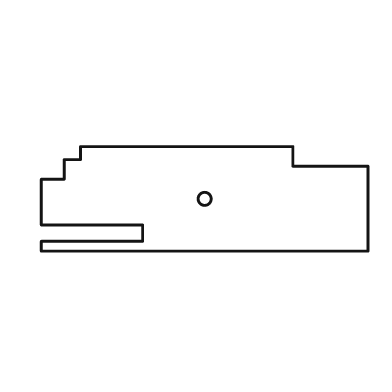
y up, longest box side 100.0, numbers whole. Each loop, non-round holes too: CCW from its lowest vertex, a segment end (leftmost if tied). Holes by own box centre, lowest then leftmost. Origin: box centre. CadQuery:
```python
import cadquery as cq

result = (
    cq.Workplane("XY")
    .moveTo(-50.0, -16.0)
    .lineTo(50.0, -16.0)
    .lineTo(50.0, 10.0)
    .lineTo(27.0, 10.0)
    .lineTo(27.0, 16.0)
    .lineTo(-38.0, 16.0)
    .lineTo(-38.0, 12.0)
    .lineTo(-43.0, 12.0)
    .lineTo(-43.0, 6.0)
    .lineTo(-50.0, 6.0)
    .lineTo(-50.0, -8.0)
    .lineTo(-19.0, -8.0)
    .lineTo(-19.0, -13.0)
    .lineTo(-50.0, -13.0)
    .close()
    .moveTo(0.0, 0.0)
    .circle(2.0)
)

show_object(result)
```